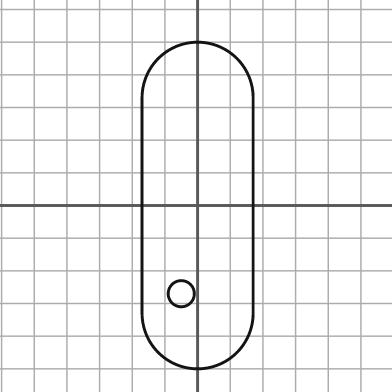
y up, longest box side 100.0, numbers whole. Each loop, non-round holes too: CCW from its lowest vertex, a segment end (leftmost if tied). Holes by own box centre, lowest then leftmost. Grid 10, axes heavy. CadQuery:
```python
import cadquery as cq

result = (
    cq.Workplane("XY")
    .moveTo(-17.0, -33.0)
    .threePointArc((0.0, -50.0), (17.0, -33.0))
    .lineTo(17.0, 33.0)
    .threePointArc((0.0, 50.0), (-17.0, 33.0))
    .close()
    .moveTo(-5.0, -27.0)
    .circle(4.0)
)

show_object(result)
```